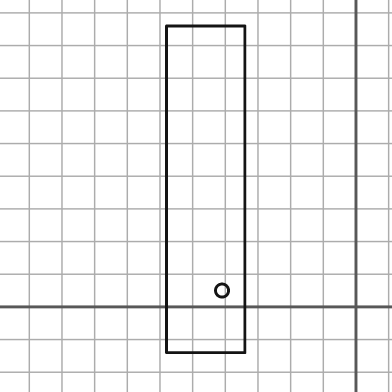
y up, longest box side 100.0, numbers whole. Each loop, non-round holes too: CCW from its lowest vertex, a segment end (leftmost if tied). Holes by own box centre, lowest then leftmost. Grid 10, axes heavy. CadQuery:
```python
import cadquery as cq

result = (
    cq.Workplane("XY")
    .moveTo(-58.0, -14.0)
    .lineTo(-34.0, -14.0)
    .lineTo(-34.0, 86.0)
    .lineTo(-58.0, 86.0)
    .close()
    .moveTo(-41.0, 5.0)
    .circle(2.0)
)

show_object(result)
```